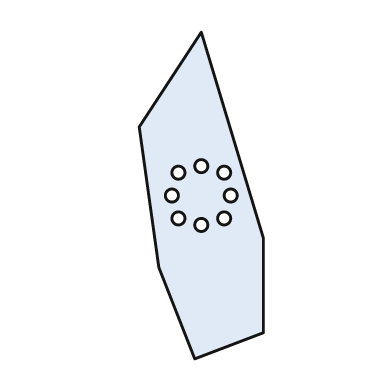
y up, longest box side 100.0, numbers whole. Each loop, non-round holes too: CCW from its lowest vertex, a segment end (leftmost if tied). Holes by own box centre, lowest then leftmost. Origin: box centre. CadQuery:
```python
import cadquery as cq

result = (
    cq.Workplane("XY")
    .moveTo(-2.0, -50.0)
    .lineTo(19.0, -42.0)
    .lineTo(19.0, -13.0)
    .lineTo(0.0, 50.0)
    .lineTo(-19.0, 21.0)
    .lineTo(-13.0, -22.0)
    .close()
    .moveTo(0.0, -9.0)
    .circle(2.0)
    .moveTo(-7.0, -7.0)
    .circle(2.0)
    .moveTo(7.0, -7.0)
    .circle(2.0)
    .moveTo(-9.0, 0.0)
    .circle(2.0)
    .moveTo(9.0, 0.0)
    .circle(2.0)
    .moveTo(-7.0, 7.0)
    .circle(2.0)
    .moveTo(7.0, 7.0)
    .circle(2.0)
    .moveTo(0.0, 9.0)
    .circle(2.0)
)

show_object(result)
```